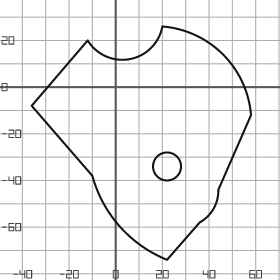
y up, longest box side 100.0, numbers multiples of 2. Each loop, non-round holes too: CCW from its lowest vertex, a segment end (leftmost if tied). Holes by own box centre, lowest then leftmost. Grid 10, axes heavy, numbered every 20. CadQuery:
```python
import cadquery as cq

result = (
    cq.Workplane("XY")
    .moveTo(22.0, -74.0)
    .lineTo(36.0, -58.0)
    .threePointArc((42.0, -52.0), (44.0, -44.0))
    .lineTo(58.0, -12.0)
    .threePointArc((46.0, 14.0), (20.0, 26.0))
    .threePointArc((6.0, 12.0), (-12.0, 20.0))
    .lineTo(-36.0, -8.0)
    .lineTo(-10.0, -38.0)
    .threePointArc((2.0, -60.0), (22.0, -74.0))
    .close()
    .moveTo(22.0, -34.0)
    .circle(6.0)
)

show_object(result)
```